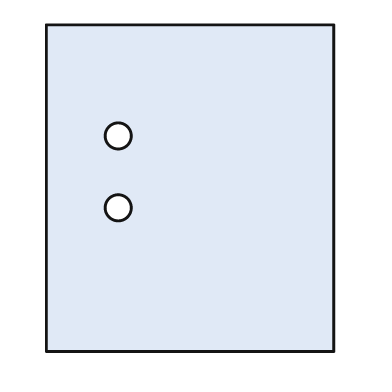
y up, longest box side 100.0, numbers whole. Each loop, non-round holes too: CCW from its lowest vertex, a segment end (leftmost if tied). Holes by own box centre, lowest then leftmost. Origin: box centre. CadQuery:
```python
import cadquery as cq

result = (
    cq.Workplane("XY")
    .moveTo(-44.0, -50.0)
    .lineTo(44.0, -50.0)
    .lineTo(44.0, 50.0)
    .lineTo(-44.0, 50.0)
    .close()
    .moveTo(-22.0, -6.0)
    .circle(4.0)
    .moveTo(-22.0, 16.0)
    .circle(4.0)
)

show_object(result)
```